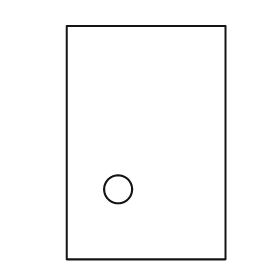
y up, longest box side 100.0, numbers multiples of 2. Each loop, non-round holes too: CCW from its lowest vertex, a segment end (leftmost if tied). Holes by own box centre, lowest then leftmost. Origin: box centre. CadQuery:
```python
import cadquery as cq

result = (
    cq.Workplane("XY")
    .moveTo(-34.0, -50.0)
    .lineTo(34.0, -50.0)
    .lineTo(34.0, 50.0)
    .lineTo(-34.0, 50.0)
    .close()
    .moveTo(-12.0, -20.0)
    .circle(6.0)
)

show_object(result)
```